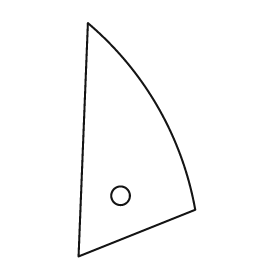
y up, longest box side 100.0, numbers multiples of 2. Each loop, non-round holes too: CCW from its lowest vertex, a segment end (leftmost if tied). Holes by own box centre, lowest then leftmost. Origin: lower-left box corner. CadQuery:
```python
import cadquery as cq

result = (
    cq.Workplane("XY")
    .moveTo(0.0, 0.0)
    .lineTo(50.0, 20.0)
    .threePointArc((34.0, 64.0), (4.0, 100.0))
    .close()
    .moveTo(18.0, 26.0)
    .circle(4.0)
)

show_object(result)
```